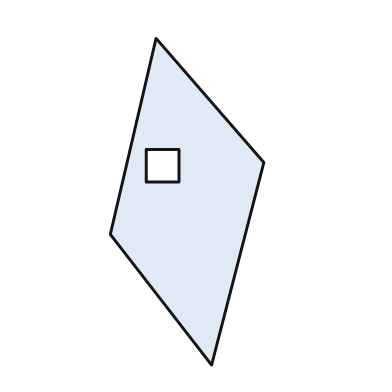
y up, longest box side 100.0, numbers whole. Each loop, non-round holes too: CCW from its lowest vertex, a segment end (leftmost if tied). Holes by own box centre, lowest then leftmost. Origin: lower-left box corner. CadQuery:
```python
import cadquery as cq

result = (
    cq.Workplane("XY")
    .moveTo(31.0, 0.0)
    .lineTo(47.0, 62.0)
    .lineTo(14.0, 100.0)
    .lineTo(0.0, 40.0)
    .close()
    .moveTo(11.0, 56.0)
    .lineTo(21.0, 56.0)
    .lineTo(21.0, 66.0)
    .lineTo(11.0, 66.0)
    .close()
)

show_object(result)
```